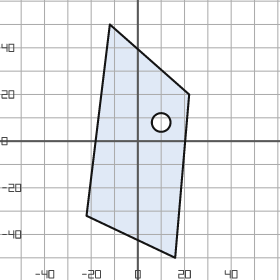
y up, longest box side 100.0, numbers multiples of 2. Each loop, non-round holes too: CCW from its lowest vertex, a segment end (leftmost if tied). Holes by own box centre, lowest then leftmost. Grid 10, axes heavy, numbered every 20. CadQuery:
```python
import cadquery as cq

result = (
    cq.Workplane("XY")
    .moveTo(16.0, -50.0)
    .lineTo(22.0, 20.0)
    .lineTo(-12.0, 50.0)
    .lineTo(-22.0, -32.0)
    .close()
    .moveTo(10.0, 8.0)
    .circle(4.0)
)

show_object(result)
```